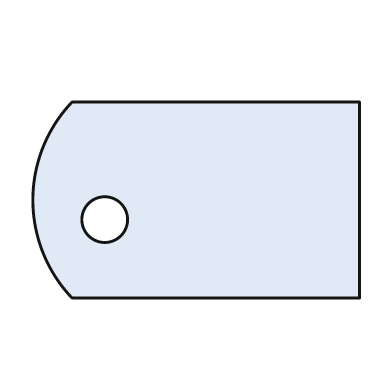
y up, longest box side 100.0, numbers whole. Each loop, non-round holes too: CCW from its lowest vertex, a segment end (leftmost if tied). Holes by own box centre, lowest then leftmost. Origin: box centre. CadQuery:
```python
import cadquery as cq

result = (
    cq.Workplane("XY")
    .moveTo(-38.0, -30.0)
    .lineTo(50.0, -30.0)
    .lineTo(50.0, 30.0)
    .lineTo(-38.0, 30.0)
    .threePointArc((-50.0, 0.0), (-38.0, -30.0))
    .close()
    .moveTo(-28.0, -6.0)
    .circle(7.0)
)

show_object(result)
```